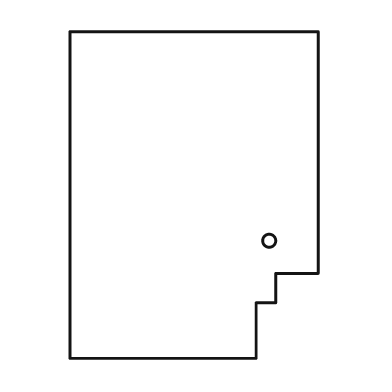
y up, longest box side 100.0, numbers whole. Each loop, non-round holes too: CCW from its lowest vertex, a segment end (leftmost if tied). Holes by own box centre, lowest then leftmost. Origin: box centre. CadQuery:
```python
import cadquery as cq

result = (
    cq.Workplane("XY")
    .moveTo(-38.0, -50.0)
    .lineTo(19.0, -50.0)
    .lineTo(19.0, -33.0)
    .lineTo(25.0, -33.0)
    .lineTo(25.0, -24.0)
    .lineTo(38.0, -24.0)
    .lineTo(38.0, 50.0)
    .lineTo(-38.0, 50.0)
    .close()
    .moveTo(23.0, -14.0)
    .circle(2.0)
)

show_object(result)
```